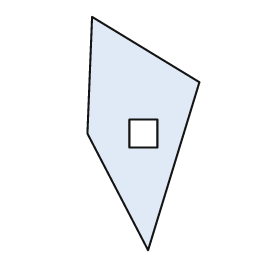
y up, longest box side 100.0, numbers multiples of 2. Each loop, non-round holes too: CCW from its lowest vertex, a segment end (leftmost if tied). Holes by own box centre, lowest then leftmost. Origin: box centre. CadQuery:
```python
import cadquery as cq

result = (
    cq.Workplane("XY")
    .moveTo(2.0, -50.0)
    .lineTo(24.0, 22.0)
    .lineTo(-22.0, 50.0)
    .lineTo(-24.0, 0.0)
    .close()
    .moveTo(-6.0, -6.0)
    .lineTo(6.0, -6.0)
    .lineTo(6.0, 6.0)
    .lineTo(-6.0, 6.0)
    .close()
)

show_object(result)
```